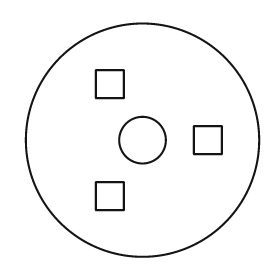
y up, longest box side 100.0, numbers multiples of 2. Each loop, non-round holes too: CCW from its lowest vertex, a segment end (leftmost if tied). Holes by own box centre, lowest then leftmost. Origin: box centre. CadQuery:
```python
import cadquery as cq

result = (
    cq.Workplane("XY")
    .moveTo(0.0, 0.0)
    .circle(50.0)
    .moveTo(-20.0, -30.0)
    .lineTo(-8.0, -30.0)
    .lineTo(-8.0, -18.0)
    .lineTo(-20.0, -18.0)
    .close()
    .moveTo(0.0, 0.0)
    .circle(10.0)
    .moveTo(22.0, -6.0)
    .lineTo(34.0, -6.0)
    .lineTo(34.0, 6.0)
    .lineTo(22.0, 6.0)
    .close()
    .moveTo(-20.0, 18.0)
    .lineTo(-8.0, 18.0)
    .lineTo(-8.0, 30.0)
    .lineTo(-20.0, 30.0)
    .close()
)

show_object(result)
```